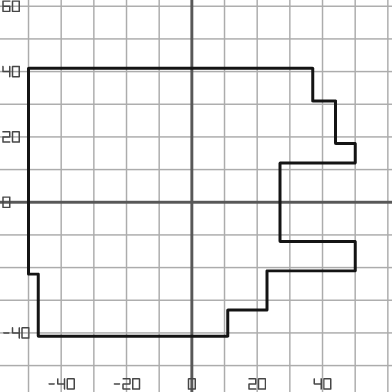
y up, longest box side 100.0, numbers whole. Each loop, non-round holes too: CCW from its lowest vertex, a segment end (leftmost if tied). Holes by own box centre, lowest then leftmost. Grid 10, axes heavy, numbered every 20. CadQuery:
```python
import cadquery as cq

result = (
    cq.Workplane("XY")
    .moveTo(-47.0, -41.0)
    .lineTo(11.0, -41.0)
    .lineTo(11.0, -33.0)
    .lineTo(23.0, -33.0)
    .lineTo(23.0, -21.0)
    .lineTo(50.0, -21.0)
    .lineTo(50.0, -12.0)
    .lineTo(27.0, -12.0)
    .lineTo(27.0, 12.0)
    .lineTo(50.0, 12.0)
    .lineTo(50.0, 18.0)
    .lineTo(44.0, 18.0)
    .lineTo(44.0, 31.0)
    .lineTo(37.0, 31.0)
    .lineTo(37.0, 41.0)
    .lineTo(-50.0, 41.0)
    .lineTo(-50.0, -22.0)
    .lineTo(-47.0, -22.0)
    .close()
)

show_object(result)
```